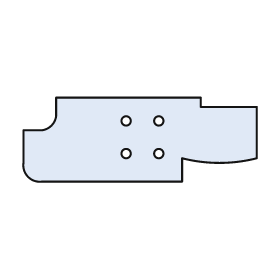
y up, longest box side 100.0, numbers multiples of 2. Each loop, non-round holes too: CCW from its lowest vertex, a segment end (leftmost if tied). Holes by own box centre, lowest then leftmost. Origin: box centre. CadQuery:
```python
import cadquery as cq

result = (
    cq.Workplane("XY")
    .moveTo(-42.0, -18.0)
    .lineTo(18.0, -18.0)
    .lineTo(18.0, -8.0)
    .threePointArc((34.0, -10.0), (50.0, -8.0))
    .lineTo(50.0, 14.0)
    .lineTo(26.0, 14.0)
    .lineTo(26.0, 18.0)
    .lineTo(-36.0, 18.0)
    .lineTo(-36.0, 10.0)
    .threePointArc((-38.0, 6.0), (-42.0, 4.0))
    .lineTo(-50.0, 4.0)
    .lineTo(-50.0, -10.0)
    .threePointArc((-48.0, -16.0), (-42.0, -18.0))
    .close()
    .moveTo(-6.0, -6.0)
    .circle(2.0)
    .moveTo(8.0, -6.0)
    .circle(2.0)
    .moveTo(-6.0, 8.0)
    .circle(2.0)
    .moveTo(8.0, 8.0)
    .circle(2.0)
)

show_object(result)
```